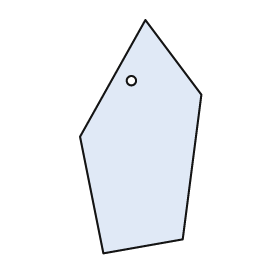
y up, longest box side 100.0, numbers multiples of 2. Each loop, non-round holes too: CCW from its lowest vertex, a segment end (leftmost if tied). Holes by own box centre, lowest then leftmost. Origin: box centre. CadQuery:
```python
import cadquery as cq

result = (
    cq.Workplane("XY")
    .moveTo(-16.0, -50.0)
    .lineTo(18.0, -44.0)
    .lineTo(26.0, 18.0)
    .lineTo(2.0, 50.0)
    .lineTo(-26.0, 0.0)
    .close()
    .moveTo(-4.0, 24.0)
    .circle(2.0)
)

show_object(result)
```